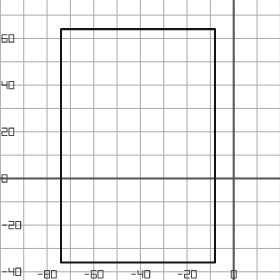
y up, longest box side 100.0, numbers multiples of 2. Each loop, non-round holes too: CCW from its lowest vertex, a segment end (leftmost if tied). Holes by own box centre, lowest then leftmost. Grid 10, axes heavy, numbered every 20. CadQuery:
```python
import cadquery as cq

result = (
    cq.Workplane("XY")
    .moveTo(-74.0, -36.0)
    .lineTo(-8.0, -36.0)
    .lineTo(-8.0, 64.0)
    .lineTo(-74.0, 64.0)
    .close()
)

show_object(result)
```